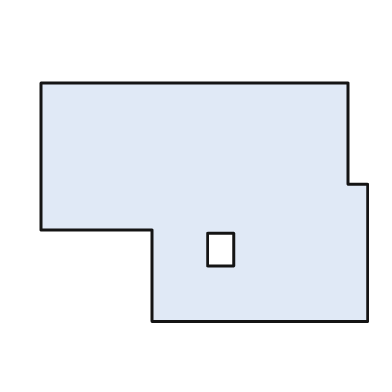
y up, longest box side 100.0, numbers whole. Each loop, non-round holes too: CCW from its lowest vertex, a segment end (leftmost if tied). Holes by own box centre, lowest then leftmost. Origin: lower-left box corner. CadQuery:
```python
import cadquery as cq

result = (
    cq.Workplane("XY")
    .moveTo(34.0, 0.0)
    .lineTo(100.0, 0.0)
    .lineTo(100.0, 42.0)
    .lineTo(94.0, 42.0)
    .lineTo(94.0, 73.0)
    .lineTo(0.0, 73.0)
    .lineTo(0.0, 28.0)
    .lineTo(34.0, 28.0)
    .close()
    .moveTo(51.0, 17.0)
    .lineTo(59.0, 17.0)
    .lineTo(59.0, 27.0)
    .lineTo(51.0, 27.0)
    .close()
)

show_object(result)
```